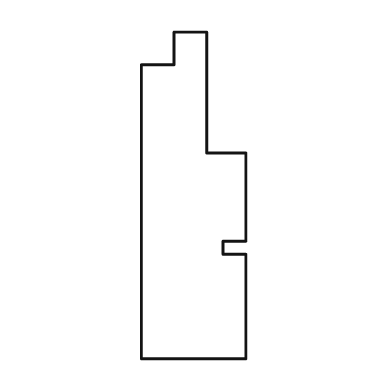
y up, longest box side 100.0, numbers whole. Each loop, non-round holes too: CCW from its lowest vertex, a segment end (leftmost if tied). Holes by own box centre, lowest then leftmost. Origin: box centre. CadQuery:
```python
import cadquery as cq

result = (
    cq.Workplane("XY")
    .moveTo(-16.0, -50.0)
    .lineTo(16.0, -50.0)
    .lineTo(16.0, -18.0)
    .lineTo(9.0, -18.0)
    .lineTo(9.0, -14.0)
    .lineTo(16.0, -14.0)
    .lineTo(16.0, 13.0)
    .lineTo(4.0, 13.0)
    .lineTo(4.0, 50.0)
    .lineTo(-6.0, 50.0)
    .lineTo(-6.0, 40.0)
    .lineTo(-16.0, 40.0)
    .close()
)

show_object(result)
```